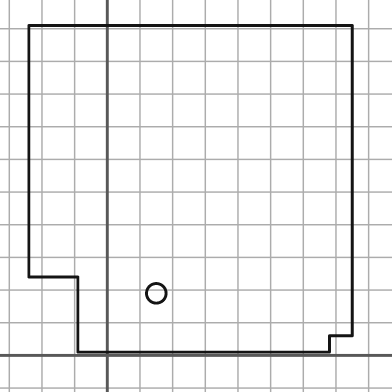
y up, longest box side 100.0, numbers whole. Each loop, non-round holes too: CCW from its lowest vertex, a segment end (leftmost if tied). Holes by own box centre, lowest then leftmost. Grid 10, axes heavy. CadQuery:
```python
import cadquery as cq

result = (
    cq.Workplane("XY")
    .moveTo(-9.0, 1.0)
    .lineTo(68.0, 1.0)
    .lineTo(68.0, 6.0)
    .lineTo(75.0, 6.0)
    .lineTo(75.0, 101.0)
    .lineTo(-24.0, 101.0)
    .lineTo(-24.0, 24.0)
    .lineTo(-9.0, 24.0)
    .close()
    .moveTo(15.0, 19.0)
    .circle(3.0)
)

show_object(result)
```